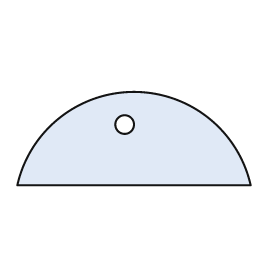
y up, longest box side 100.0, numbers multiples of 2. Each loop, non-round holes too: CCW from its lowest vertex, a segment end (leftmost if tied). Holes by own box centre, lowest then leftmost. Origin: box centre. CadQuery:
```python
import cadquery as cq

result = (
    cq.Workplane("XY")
    .moveTo(-50.0, -20.0)
    .lineTo(50.0, -20.0)
    .threePointArc((0.0, 20.0), (-50.0, -20.0))
    .close()
    .moveTo(-4.0, 6.0)
    .circle(4.0)
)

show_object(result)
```